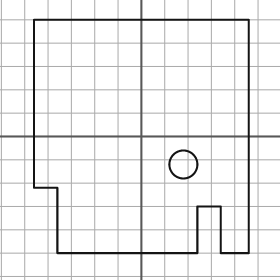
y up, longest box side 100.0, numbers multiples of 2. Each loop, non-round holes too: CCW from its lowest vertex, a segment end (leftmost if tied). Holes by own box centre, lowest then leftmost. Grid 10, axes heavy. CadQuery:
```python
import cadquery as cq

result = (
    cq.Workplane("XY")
    .moveTo(-36.0, -50.0)
    .lineTo(24.0, -50.0)
    .lineTo(24.0, -30.0)
    .lineTo(34.0, -30.0)
    .lineTo(34.0, -50.0)
    .lineTo(46.0, -50.0)
    .lineTo(46.0, 50.0)
    .lineTo(-46.0, 50.0)
    .lineTo(-46.0, -22.0)
    .lineTo(-36.0, -22.0)
    .close()
    .moveTo(18.0, -12.0)
    .circle(6.0)
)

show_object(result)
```